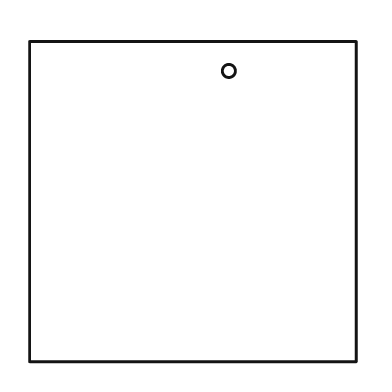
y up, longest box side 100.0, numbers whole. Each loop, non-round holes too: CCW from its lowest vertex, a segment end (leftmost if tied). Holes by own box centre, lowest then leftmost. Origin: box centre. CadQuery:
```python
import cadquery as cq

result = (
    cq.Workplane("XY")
    .moveTo(-50.0, -49.0)
    .lineTo(50.0, -49.0)
    .lineTo(50.0, 49.0)
    .lineTo(-50.0, 49.0)
    .close()
    .moveTo(11.0, 40.0)
    .circle(2.0)
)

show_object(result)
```